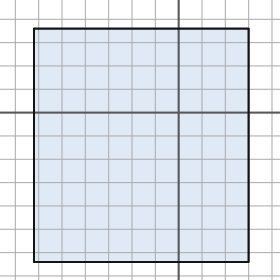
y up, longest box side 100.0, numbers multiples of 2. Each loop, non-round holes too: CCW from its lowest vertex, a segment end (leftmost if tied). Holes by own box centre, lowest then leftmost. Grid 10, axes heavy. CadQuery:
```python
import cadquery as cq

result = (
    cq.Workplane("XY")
    .moveTo(-62.0, -64.0)
    .lineTo(30.0, -64.0)
    .lineTo(30.0, 36.0)
    .lineTo(-62.0, 36.0)
    .close()
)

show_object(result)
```